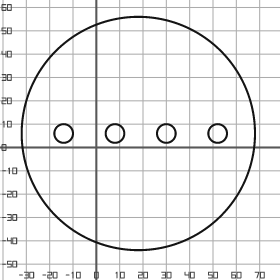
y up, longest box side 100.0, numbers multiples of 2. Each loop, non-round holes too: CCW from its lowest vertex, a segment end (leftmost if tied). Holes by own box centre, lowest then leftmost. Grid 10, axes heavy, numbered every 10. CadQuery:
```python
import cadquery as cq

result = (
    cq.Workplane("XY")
    .moveTo(18.0, 6.0)
    .circle(50.0)
    .moveTo(-14.0, 6.0)
    .circle(4.0)
    .moveTo(8.0, 6.0)
    .circle(4.0)
    .moveTo(30.0, 6.0)
    .circle(4.0)
    .moveTo(52.0, 6.0)
    .circle(4.0)
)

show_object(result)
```